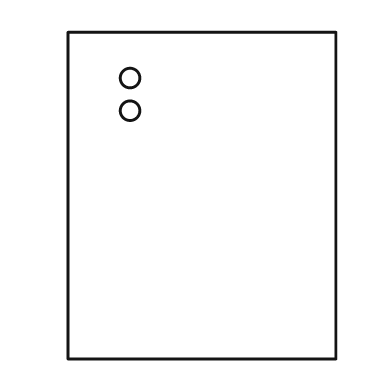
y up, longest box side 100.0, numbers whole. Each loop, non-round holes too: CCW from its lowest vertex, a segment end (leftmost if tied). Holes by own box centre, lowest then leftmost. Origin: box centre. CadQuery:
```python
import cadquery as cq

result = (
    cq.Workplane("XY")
    .moveTo(-41.0, -50.0)
    .lineTo(41.0, -50.0)
    .lineTo(41.0, 50.0)
    .lineTo(-41.0, 50.0)
    .close()
    .moveTo(-22.0, 26.0)
    .circle(3.0)
    .moveTo(-22.0, 36.0)
    .circle(3.0)
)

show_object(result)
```